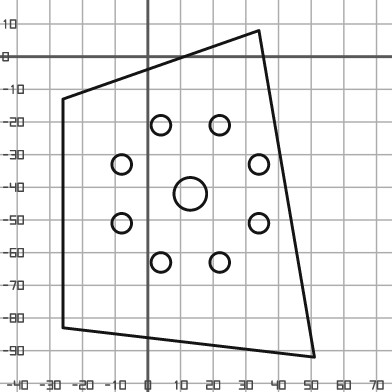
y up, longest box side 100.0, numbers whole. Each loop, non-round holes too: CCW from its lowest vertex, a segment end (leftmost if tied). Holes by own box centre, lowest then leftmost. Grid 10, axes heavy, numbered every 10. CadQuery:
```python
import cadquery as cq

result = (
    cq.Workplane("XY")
    .moveTo(51.0, -92.0)
    .lineTo(34.0, 8.0)
    .lineTo(-26.0, -13.0)
    .lineTo(-26.0, -83.0)
    .close()
    .moveTo(4.0, -63.0)
    .circle(3.0)
    .moveTo(22.0, -63.0)
    .circle(3.0)
    .moveTo(-8.0, -51.0)
    .circle(3.0)
    .moveTo(34.0, -51.0)
    .circle(3.0)
    .moveTo(13.0, -42.0)
    .circle(5.0)
    .moveTo(-8.0, -33.0)
    .circle(3.0)
    .moveTo(34.0, -33.0)
    .circle(3.0)
    .moveTo(4.0, -21.0)
    .circle(3.0)
    .moveTo(22.0, -21.0)
    .circle(3.0)
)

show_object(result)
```